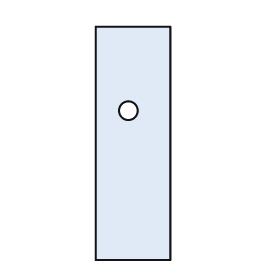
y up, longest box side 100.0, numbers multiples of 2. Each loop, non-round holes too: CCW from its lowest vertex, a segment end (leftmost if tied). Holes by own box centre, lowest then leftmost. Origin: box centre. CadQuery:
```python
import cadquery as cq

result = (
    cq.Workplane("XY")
    .moveTo(-16.0, -50.0)
    .lineTo(16.0, -50.0)
    .lineTo(16.0, 50.0)
    .lineTo(-16.0, 50.0)
    .close()
    .moveTo(-2.0, 14.0)
    .circle(4.0)
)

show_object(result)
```